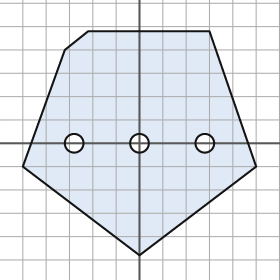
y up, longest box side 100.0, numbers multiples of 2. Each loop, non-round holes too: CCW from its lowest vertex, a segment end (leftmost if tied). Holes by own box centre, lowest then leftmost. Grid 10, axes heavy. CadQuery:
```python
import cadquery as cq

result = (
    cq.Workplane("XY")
    .moveTo(0.0, -48.0)
    .lineTo(50.0, -10.0)
    .lineTo(30.0, 48.0)
    .lineTo(-22.0, 48.0)
    .lineTo(-32.0, 40.0)
    .lineTo(-50.0, -10.0)
    .close()
    .moveTo(-28.0, 0.0)
    .circle(4.0)
    .moveTo(0.0, 0.0)
    .circle(4.0)
    .moveTo(28.0, 0.0)
    .circle(4.0)
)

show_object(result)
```